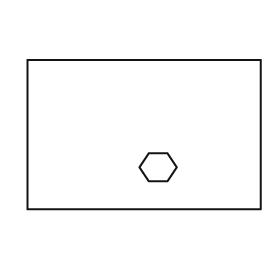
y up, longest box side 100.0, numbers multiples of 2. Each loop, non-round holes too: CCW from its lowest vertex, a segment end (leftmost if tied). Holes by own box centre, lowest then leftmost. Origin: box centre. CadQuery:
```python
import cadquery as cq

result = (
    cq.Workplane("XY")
    .moveTo(-50.0, -32.0)
    .lineTo(50.0, -32.0)
    .lineTo(50.0, 32.0)
    .lineTo(-50.0, 32.0)
    .close()
    .moveTo(2.0, -20.0)
    .lineTo(10.0, -20.0)
    .lineTo(14.0, -14.0)
    .lineTo(10.0, -8.0)
    .lineTo(2.0, -8.0)
    .lineTo(-2.0, -14.0)
    .close()
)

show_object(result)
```